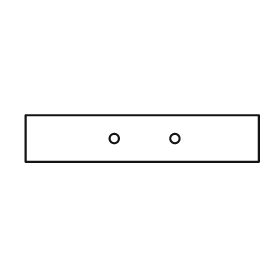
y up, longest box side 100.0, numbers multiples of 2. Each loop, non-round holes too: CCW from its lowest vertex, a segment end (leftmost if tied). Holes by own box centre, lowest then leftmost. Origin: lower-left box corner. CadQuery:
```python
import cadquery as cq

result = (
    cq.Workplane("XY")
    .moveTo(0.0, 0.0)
    .lineTo(100.0, 0.0)
    .lineTo(100.0, 20.0)
    .lineTo(0.0, 20.0)
    .close()
    .moveTo(38.0, 10.0)
    .circle(2.0)
    .moveTo(64.0, 10.0)
    .circle(2.0)
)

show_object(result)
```